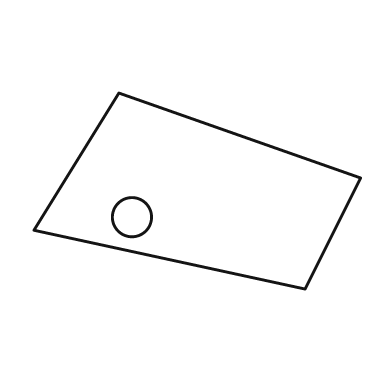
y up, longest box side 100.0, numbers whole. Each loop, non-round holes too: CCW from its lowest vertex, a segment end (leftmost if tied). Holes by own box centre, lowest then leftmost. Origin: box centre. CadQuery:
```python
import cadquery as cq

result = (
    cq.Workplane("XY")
    .moveTo(33.0, -30.0)
    .lineTo(50.0, 4.0)
    .lineTo(-24.0, 30.0)
    .lineTo(-50.0, -12.0)
    .close()
    .moveTo(-20.0, -8.0)
    .circle(6.0)
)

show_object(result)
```